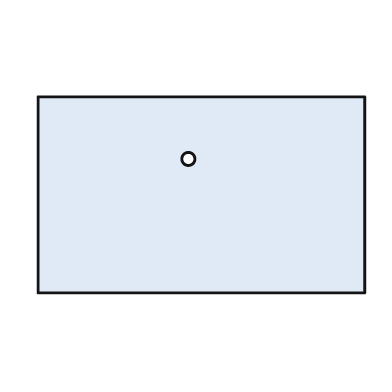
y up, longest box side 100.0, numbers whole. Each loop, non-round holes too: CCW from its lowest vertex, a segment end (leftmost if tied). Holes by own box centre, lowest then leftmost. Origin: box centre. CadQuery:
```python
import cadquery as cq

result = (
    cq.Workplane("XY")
    .moveTo(-50.0, -30.0)
    .lineTo(50.0, -30.0)
    .lineTo(50.0, 30.0)
    .lineTo(-50.0, 30.0)
    .close()
    .moveTo(-4.0, 11.0)
    .circle(2.0)
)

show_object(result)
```